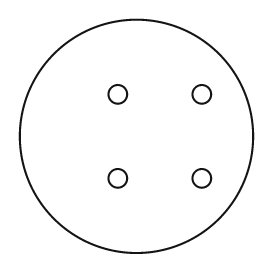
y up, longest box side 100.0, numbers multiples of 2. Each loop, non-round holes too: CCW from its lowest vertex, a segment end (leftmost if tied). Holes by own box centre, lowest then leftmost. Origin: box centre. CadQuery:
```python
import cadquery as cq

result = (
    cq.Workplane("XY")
    .moveTo(0.0, 0.0)
    .circle(50.0)
    .moveTo(-8.0, -18.0)
    .circle(4.0)
    .moveTo(28.0, -18.0)
    .circle(4.0)
    .moveTo(-8.0, 18.0)
    .circle(4.0)
    .moveTo(28.0, 18.0)
    .circle(4.0)
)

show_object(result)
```